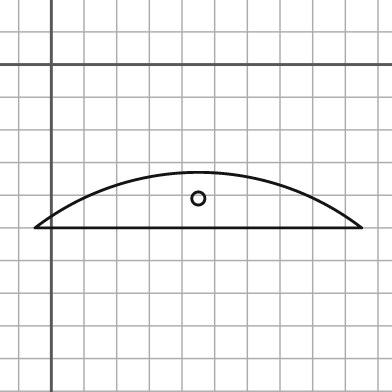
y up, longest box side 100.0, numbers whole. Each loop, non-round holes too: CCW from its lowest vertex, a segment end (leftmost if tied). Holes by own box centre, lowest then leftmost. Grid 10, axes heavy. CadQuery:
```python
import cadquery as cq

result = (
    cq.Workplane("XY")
    .moveTo(-5.0, -50.0)
    .lineTo(95.0, -50.0)
    .threePointArc((45.0, -33.0), (-5.0, -50.0))
    .close()
    .moveTo(45.0, -41.0)
    .circle(2.0)
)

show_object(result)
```